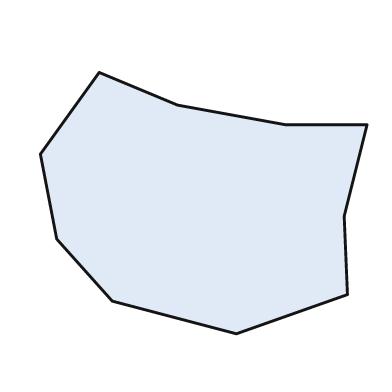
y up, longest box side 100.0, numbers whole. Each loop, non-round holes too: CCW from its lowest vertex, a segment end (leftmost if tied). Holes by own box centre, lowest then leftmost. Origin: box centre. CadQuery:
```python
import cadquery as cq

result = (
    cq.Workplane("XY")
    .moveTo(10.0, -40.0)
    .lineTo(44.0, -28.0)
    .lineTo(43.0, -4.0)
    .lineTo(50.0, 24.0)
    .lineTo(25.0, 24.0)
    .lineTo(-8.0, 30.0)
    .lineTo(-32.0, 40.0)
    .lineTo(-50.0, 15.0)
    .lineTo(-45.0, -11.0)
    .lineTo(-28.0, -30.0)
    .close()
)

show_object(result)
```